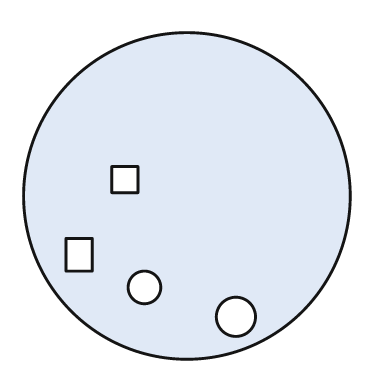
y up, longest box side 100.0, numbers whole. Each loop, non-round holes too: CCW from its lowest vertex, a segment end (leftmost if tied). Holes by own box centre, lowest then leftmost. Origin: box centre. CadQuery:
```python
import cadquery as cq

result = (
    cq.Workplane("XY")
    .moveTo(0.0, 0.0)
    .circle(50.0)
    .moveTo(15.0, -37.0)
    .circle(6.0)
    .moveTo(-13.0, -28.0)
    .circle(5.0)
    .moveTo(-37.0, -23.0)
    .lineTo(-29.0, -23.0)
    .lineTo(-29.0, -13.0)
    .lineTo(-37.0, -13.0)
    .close()
    .moveTo(-23.0, 1.0)
    .lineTo(-15.0, 1.0)
    .lineTo(-15.0, 9.0)
    .lineTo(-23.0, 9.0)
    .close()
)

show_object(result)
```